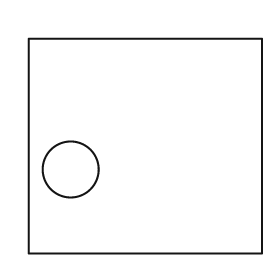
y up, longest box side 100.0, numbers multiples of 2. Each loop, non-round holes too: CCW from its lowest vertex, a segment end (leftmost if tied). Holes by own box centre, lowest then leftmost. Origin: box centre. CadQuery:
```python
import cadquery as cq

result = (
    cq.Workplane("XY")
    .moveTo(-50.0, -46.0)
    .lineTo(50.0, -46.0)
    .lineTo(50.0, 46.0)
    .lineTo(-50.0, 46.0)
    .close()
    .moveTo(-32.0, -10.0)
    .circle(12.0)
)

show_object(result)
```